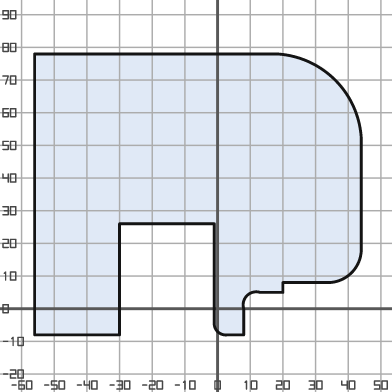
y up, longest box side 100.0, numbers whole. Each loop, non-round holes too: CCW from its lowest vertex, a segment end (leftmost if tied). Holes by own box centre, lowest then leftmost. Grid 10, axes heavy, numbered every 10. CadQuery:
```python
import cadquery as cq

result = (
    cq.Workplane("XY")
    .moveTo(-56.0, -8.0)
    .lineTo(-30.0, -8.0)
    .lineTo(-30.0, 26.0)
    .lineTo(-1.0, 26.0)
    .lineTo(-1.0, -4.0)
    .threePointArc((0.0, -7.0), (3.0, -8.0))
    .lineTo(8.0, -8.0)
    .lineTo(8.0, 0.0)
    .threePointArc((9.0, 4.0), (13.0, 5.0))
    .lineTo(20.0, 5.0)
    .lineTo(20.0, 8.0)
    .lineTo(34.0, 8.0)
    .threePointArc((41.0, 11.0), (44.0, 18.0))
    .lineTo(44.0, 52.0)
    .threePointArc((36.0, 70.0), (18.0, 78.0))
    .lineTo(-56.0, 78.0)
    .close()
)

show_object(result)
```